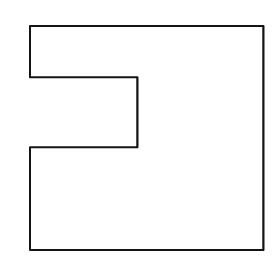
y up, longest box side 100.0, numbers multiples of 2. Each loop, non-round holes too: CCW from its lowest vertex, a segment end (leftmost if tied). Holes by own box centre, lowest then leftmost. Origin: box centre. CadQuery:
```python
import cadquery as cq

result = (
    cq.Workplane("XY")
    .moveTo(-50.0, -48.0)
    .lineTo(50.0, -48.0)
    .lineTo(50.0, 48.0)
    .lineTo(-50.0, 48.0)
    .lineTo(-50.0, 26.0)
    .lineTo(-4.0, 26.0)
    .lineTo(-4.0, -4.0)
    .lineTo(-50.0, -4.0)
    .close()
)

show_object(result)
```